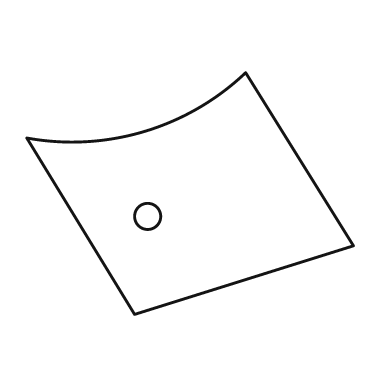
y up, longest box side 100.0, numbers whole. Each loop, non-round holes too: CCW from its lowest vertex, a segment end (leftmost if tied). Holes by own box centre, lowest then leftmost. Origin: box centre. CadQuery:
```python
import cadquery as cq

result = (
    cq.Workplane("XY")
    .moveTo(-17.0, -37.0)
    .lineTo(50.0, -16.0)
    .lineTo(17.0, 37.0)
    .threePointArc((-14.0, 19.0), (-50.0, 17.0))
    .close()
    .moveTo(-13.0, -7.0)
    .circle(4.0)
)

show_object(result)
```